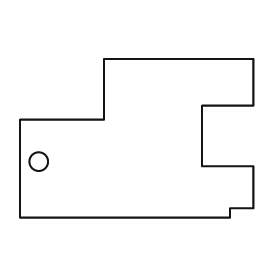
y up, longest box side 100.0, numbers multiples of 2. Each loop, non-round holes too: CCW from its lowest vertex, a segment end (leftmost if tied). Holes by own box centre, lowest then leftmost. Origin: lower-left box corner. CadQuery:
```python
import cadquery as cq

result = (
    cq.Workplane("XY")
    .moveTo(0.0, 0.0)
    .lineTo(90.0, 0.0)
    .lineTo(90.0, 4.0)
    .lineTo(100.0, 4.0)
    .lineTo(100.0, 22.0)
    .lineTo(78.0, 22.0)
    .lineTo(78.0, 48.0)
    .lineTo(100.0, 48.0)
    .lineTo(100.0, 68.0)
    .lineTo(36.0, 68.0)
    .lineTo(36.0, 42.0)
    .lineTo(0.0, 42.0)
    .close()
    .moveTo(8.0, 24.0)
    .circle(4.0)
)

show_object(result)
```